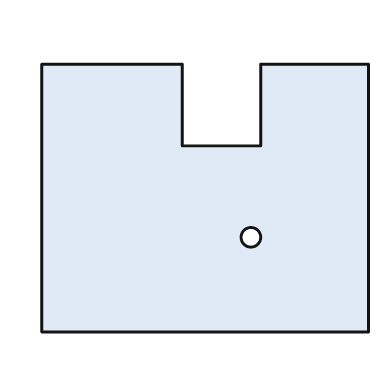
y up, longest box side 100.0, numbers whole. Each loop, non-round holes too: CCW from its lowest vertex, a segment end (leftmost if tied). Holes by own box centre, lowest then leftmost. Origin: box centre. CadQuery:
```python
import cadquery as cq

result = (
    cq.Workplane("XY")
    .moveTo(-50.0, -41.0)
    .lineTo(50.0, -41.0)
    .lineTo(50.0, 41.0)
    .lineTo(17.0, 41.0)
    .lineTo(17.0, 16.0)
    .lineTo(-7.0, 16.0)
    .lineTo(-7.0, 41.0)
    .lineTo(-50.0, 41.0)
    .close()
    .moveTo(14.0, -12.0)
    .circle(3.0)
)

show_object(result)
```